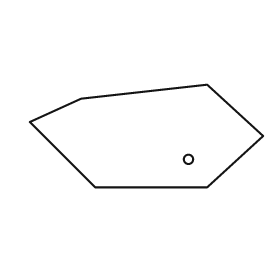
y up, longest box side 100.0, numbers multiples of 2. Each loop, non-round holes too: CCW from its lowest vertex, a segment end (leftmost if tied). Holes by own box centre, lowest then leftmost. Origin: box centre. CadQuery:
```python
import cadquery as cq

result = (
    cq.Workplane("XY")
    .moveTo(-22.0, -22.0)
    .lineTo(26.0, -22.0)
    .lineTo(50.0, 0.0)
    .lineTo(26.0, 22.0)
    .lineTo(-28.0, 16.0)
    .lineTo(-50.0, 6.0)
    .close()
    .moveTo(18.0, -10.0)
    .circle(2.0)
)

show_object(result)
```